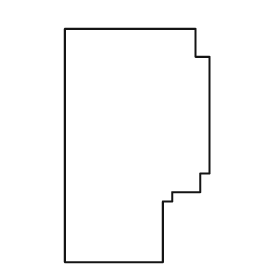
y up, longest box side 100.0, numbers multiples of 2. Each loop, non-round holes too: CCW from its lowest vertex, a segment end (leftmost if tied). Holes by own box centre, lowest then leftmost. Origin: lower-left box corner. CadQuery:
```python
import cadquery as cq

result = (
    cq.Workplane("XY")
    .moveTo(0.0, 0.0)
    .lineTo(42.0, 0.0)
    .lineTo(42.0, 26.0)
    .lineTo(46.0, 26.0)
    .lineTo(46.0, 30.0)
    .lineTo(58.0, 30.0)
    .lineTo(58.0, 38.0)
    .lineTo(62.0, 38.0)
    .lineTo(62.0, 88.0)
    .lineTo(56.0, 88.0)
    .lineTo(56.0, 100.0)
    .lineTo(0.0, 100.0)
    .close()
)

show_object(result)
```